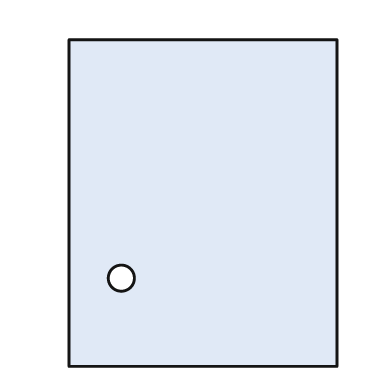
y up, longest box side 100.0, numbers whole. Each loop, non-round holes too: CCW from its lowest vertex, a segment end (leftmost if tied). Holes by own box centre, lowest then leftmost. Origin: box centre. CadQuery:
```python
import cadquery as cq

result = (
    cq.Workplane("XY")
    .moveTo(-41.0, -50.0)
    .lineTo(41.0, -50.0)
    .lineTo(41.0, 50.0)
    .lineTo(-41.0, 50.0)
    .close()
    .moveTo(-25.0, -23.0)
    .circle(4.0)
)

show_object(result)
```